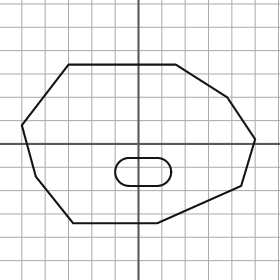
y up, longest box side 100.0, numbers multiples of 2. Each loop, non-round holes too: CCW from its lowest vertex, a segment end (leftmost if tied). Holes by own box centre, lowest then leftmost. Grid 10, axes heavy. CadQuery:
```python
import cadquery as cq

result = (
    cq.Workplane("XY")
    .moveTo(-28.0, -34.0)
    .lineTo(8.0, -34.0)
    .lineTo(44.0, -18.0)
    .lineTo(50.0, 2.0)
    .lineTo(38.0, 20.0)
    .lineTo(16.0, 34.0)
    .lineTo(-30.0, 34.0)
    .lineTo(-50.0, 8.0)
    .lineTo(-44.0, -14.0)
    .close()
    .moveTo(-4.0, -18.0)
    .lineTo(8.0, -18.0)
    .threePointArc((14.0, -12.0), (8.0, -6.0))
    .lineTo(-4.0, -6.0)
    .threePointArc((-10.0, -12.0), (-4.0, -18.0))
    .close()
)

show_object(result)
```